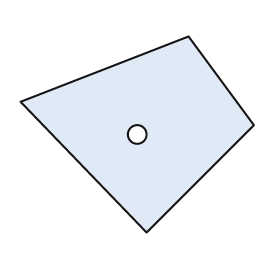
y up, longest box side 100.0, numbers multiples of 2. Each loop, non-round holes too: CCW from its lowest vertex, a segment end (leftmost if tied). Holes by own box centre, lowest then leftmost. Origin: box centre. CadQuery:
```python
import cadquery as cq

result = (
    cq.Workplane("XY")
    .moveTo(4.0, -42.0)
    .lineTo(50.0, 4.0)
    .lineTo(22.0, 42.0)
    .lineTo(-50.0, 14.0)
    .close()
    .moveTo(0.0, 0.0)
    .circle(4.0)
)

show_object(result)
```